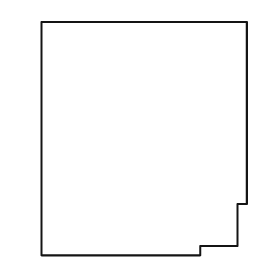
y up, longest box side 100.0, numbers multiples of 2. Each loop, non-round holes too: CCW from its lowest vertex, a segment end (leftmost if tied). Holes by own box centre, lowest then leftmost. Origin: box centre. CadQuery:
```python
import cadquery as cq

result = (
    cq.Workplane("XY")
    .moveTo(-44.0, -50.0)
    .lineTo(24.0, -50.0)
    .lineTo(24.0, -46.0)
    .lineTo(40.0, -46.0)
    .lineTo(40.0, -28.0)
    .lineTo(44.0, -28.0)
    .lineTo(44.0, 50.0)
    .lineTo(-44.0, 50.0)
    .close()
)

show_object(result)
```